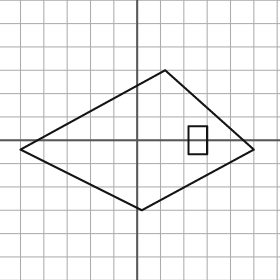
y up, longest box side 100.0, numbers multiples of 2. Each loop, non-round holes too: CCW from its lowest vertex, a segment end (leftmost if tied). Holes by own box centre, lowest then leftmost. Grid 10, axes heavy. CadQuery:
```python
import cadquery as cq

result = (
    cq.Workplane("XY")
    .moveTo(2.0, -30.0)
    .lineTo(50.0, -4.0)
    .lineTo(12.0, 30.0)
    .lineTo(-50.0, -4.0)
    .close()
    .moveTo(22.0, -6.0)
    .lineTo(30.0, -6.0)
    .lineTo(30.0, 6.0)
    .lineTo(22.0, 6.0)
    .close()
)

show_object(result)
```